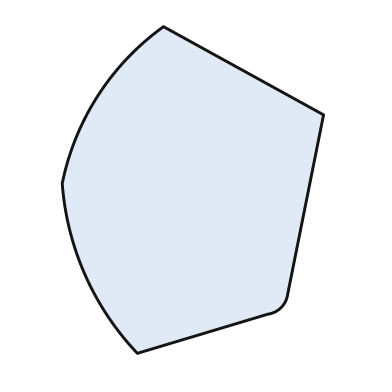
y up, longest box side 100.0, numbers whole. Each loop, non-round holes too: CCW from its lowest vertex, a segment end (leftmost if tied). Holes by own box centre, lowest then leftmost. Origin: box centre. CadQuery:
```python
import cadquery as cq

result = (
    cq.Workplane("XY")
    .moveTo(-17.0, -50.0)
    .lineTo(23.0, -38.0)
    .threePointArc((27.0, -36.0), (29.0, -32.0))
    .lineTo(40.0, 23.0)
    .lineTo(-9.0, 50.0)
    .threePointArc((-29.0, 29.0), (-40.0, 2.0))
    .threePointArc((-33.0, -26.0), (-17.0, -50.0))
    .close()
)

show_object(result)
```